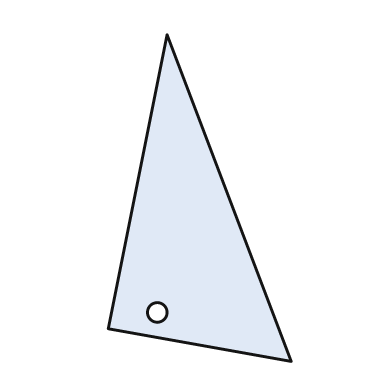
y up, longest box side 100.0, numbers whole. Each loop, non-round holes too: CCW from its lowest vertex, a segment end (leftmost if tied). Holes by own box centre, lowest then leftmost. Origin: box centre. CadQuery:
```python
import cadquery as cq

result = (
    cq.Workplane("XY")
    .moveTo(28.0, -50.0)
    .lineTo(-10.0, 50.0)
    .lineTo(-28.0, -40.0)
    .close()
    .moveTo(-13.0, -35.0)
    .circle(3.0)
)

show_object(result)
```